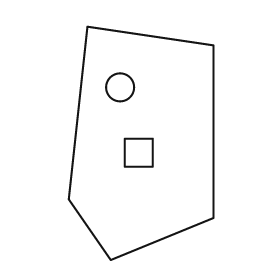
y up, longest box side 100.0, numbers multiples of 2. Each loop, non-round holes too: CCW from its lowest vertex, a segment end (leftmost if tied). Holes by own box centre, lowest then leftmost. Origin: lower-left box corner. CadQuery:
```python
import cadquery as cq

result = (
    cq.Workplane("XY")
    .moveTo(18.0, 0.0)
    .lineTo(62.0, 18.0)
    .lineTo(62.0, 92.0)
    .lineTo(8.0, 100.0)
    .lineTo(0.0, 26.0)
    .close()
    .moveTo(24.0, 40.0)
    .lineTo(36.0, 40.0)
    .lineTo(36.0, 52.0)
    .lineTo(24.0, 52.0)
    .close()
    .moveTo(22.0, 74.0)
    .circle(6.0)
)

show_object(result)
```